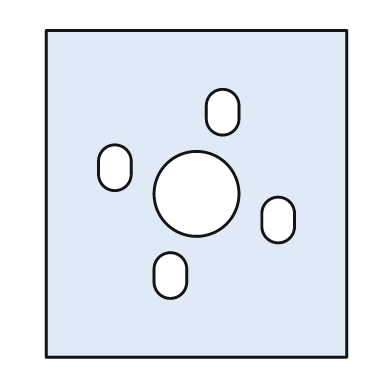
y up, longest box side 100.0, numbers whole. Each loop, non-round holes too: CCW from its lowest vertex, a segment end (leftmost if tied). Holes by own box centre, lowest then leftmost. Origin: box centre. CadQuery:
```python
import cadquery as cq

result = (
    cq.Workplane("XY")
    .moveTo(-46.0, -50.0)
    .lineTo(46.0, -50.0)
    .lineTo(46.0, 50.0)
    .lineTo(-46.0, 50.0)
    .close()
    .moveTo(-13.0, -27.0)
    .threePointArc((-8.0, -32.0), (-3.0, -27.0))
    .lineTo(-3.0, -23.0)
    .threePointArc((-8.0, -18.0), (-13.0, -23.0))
    .close()
    .moveTo(20.0, -10.0)
    .threePointArc((25.0, -15.0), (30.0, -10.0))
    .lineTo(30.0, -6.0)
    .threePointArc((25.0, -1.0), (20.0, -6.0))
    .close()
    .moveTo(0.0, 0.0)
    .circle(13.0)
    .moveTo(-30.0, 6.0)
    .threePointArc((-25.0, 1.0), (-20.0, 6.0))
    .lineTo(-20.0, 10.0)
    .threePointArc((-25.0, 15.0), (-30.0, 10.0))
    .close()
    .moveTo(3.0, 23.0)
    .threePointArc((8.0, 18.0), (13.0, 23.0))
    .lineTo(13.0, 27.0)
    .threePointArc((8.0, 32.0), (3.0, 27.0))
    .close()
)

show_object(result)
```